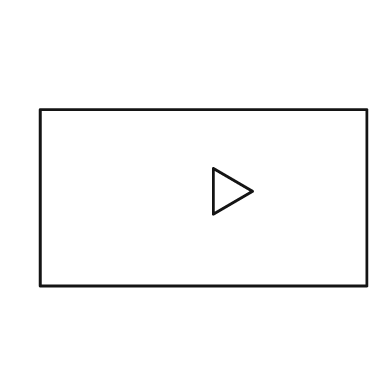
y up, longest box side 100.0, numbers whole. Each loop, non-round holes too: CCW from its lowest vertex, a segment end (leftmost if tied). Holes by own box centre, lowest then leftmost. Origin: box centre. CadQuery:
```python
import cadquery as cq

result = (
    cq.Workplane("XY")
    .moveTo(-50.0, -27.0)
    .lineTo(50.0, -27.0)
    .lineTo(50.0, 27.0)
    .lineTo(-50.0, 27.0)
    .close()
    .moveTo(3.0, -5.0)
    .lineTo(15.0, 2.0)
    .lineTo(3.0, 9.0)
    .close()
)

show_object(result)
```